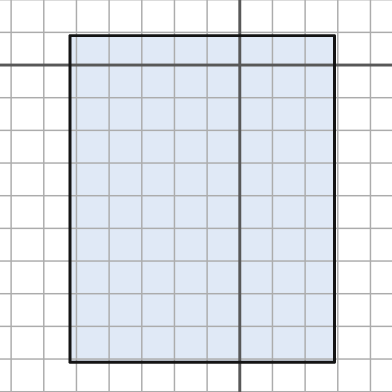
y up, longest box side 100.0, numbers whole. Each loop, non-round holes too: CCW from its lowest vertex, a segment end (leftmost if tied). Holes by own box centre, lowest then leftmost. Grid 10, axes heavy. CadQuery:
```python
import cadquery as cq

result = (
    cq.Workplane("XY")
    .moveTo(-52.0, -91.0)
    .lineTo(29.0, -91.0)
    .lineTo(29.0, 9.0)
    .lineTo(-52.0, 9.0)
    .close()
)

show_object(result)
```